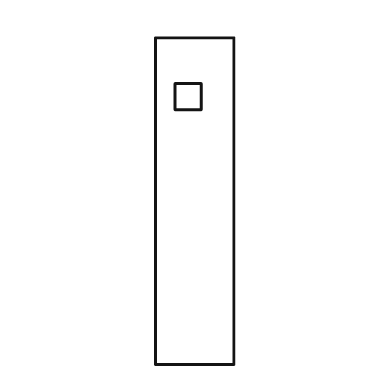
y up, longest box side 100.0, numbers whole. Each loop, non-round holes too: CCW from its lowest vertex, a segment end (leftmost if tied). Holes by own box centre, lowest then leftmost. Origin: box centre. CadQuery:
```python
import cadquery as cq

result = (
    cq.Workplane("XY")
    .moveTo(-12.0, -50.0)
    .lineTo(12.0, -50.0)
    .lineTo(12.0, 50.0)
    .lineTo(-12.0, 50.0)
    .close()
    .moveTo(-6.0, 28.0)
    .lineTo(2.0, 28.0)
    .lineTo(2.0, 36.0)
    .lineTo(-6.0, 36.0)
    .close()
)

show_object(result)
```